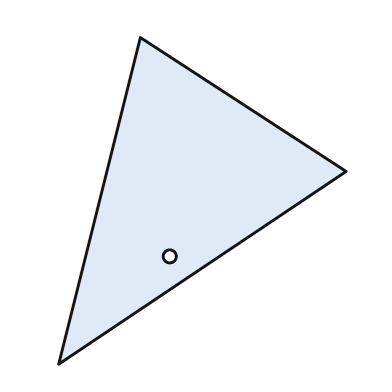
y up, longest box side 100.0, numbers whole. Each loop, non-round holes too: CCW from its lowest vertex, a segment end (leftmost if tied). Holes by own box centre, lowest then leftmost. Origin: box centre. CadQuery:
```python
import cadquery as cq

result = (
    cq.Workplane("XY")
    .moveTo(-44.0, -50.0)
    .lineTo(44.0, 9.0)
    .lineTo(-19.0, 50.0)
    .close()
    .moveTo(-10.0, -17.0)
    .circle(2.0)
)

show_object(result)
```